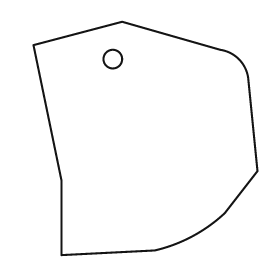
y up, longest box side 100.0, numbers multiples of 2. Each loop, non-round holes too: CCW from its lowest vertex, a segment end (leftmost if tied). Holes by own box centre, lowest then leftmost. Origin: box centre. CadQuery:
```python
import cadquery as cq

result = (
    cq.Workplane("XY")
    .moveTo(-36.0, -50.0)
    .lineTo(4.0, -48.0)
    .threePointArc((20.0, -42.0), (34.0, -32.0))
    .lineTo(48.0, -14.0)
    .lineTo(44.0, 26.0)
    .threePointArc((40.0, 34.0), (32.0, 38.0))
    .lineTo(-10.0, 50.0)
    .lineTo(-48.0, 40.0)
    .lineTo(-36.0, -18.0)
    .close()
    .moveTo(-14.0, 34.0)
    .circle(4.0)
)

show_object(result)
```